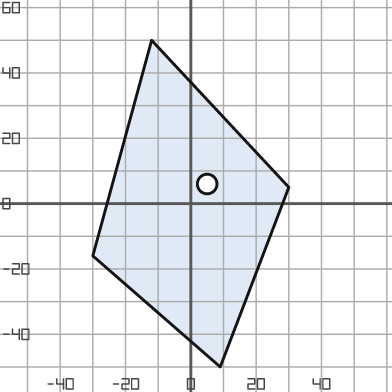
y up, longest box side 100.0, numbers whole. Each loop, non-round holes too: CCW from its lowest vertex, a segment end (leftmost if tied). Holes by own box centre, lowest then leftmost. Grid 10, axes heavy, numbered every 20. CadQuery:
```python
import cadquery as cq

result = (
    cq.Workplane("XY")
    .moveTo(9.0, -50.0)
    .lineTo(30.0, 5.0)
    .lineTo(-12.0, 50.0)
    .lineTo(-30.0, -16.0)
    .close()
    .moveTo(5.0, 6.0)
    .circle(3.0)
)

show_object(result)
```